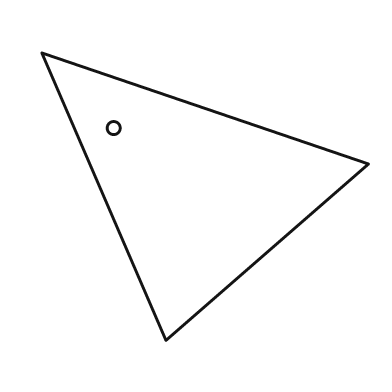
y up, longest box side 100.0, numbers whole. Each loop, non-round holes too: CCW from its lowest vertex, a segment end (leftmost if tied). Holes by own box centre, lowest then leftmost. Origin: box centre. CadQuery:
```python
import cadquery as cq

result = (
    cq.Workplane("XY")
    .moveTo(-12.0, -44.0)
    .lineTo(50.0, 10.0)
    .lineTo(-50.0, 44.0)
    .close()
    .moveTo(-28.0, 21.0)
    .circle(2.0)
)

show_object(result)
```